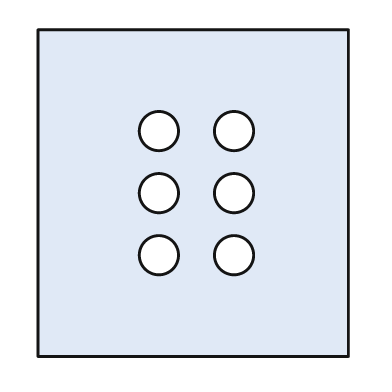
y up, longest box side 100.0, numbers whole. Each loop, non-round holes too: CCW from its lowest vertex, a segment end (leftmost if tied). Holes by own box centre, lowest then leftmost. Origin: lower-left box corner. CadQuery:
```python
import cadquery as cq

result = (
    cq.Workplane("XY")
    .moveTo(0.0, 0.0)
    .lineTo(95.0, 0.0)
    .lineTo(95.0, 100.0)
    .lineTo(0.0, 100.0)
    .close()
    .moveTo(37.0, 31.0)
    .circle(6.0)
    .moveTo(60.0, 31.0)
    .circle(6.0)
    .moveTo(37.0, 50.0)
    .circle(6.0)
    .moveTo(60.0, 50.0)
    .circle(6.0)
    .moveTo(37.0, 69.0)
    .circle(6.0)
    .moveTo(60.0, 69.0)
    .circle(6.0)
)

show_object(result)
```